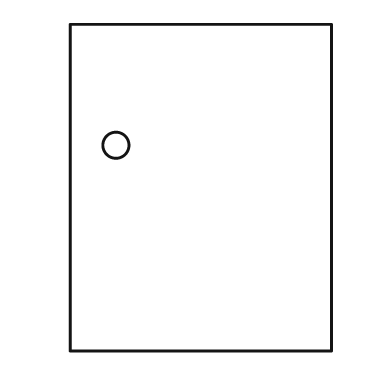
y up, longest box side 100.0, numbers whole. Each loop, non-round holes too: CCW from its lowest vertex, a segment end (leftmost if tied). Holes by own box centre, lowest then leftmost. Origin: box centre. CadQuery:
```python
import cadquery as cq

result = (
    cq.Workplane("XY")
    .moveTo(-40.0, -50.0)
    .lineTo(40.0, -50.0)
    .lineTo(40.0, 50.0)
    .lineTo(-40.0, 50.0)
    .close()
    .moveTo(-26.0, 13.0)
    .circle(4.0)
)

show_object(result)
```